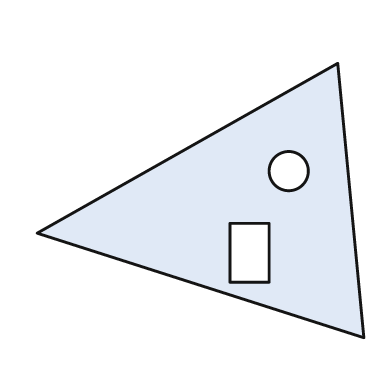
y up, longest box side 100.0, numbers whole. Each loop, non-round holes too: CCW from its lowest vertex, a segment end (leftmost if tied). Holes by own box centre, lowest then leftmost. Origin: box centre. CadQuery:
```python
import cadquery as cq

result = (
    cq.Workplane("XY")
    .moveTo(50.0, -42.0)
    .lineTo(42.0, 42.0)
    .lineTo(-50.0, -10.0)
    .close()
    .moveTo(9.0, -25.0)
    .lineTo(21.0, -25.0)
    .lineTo(21.0, -7.0)
    .lineTo(9.0, -7.0)
    .close()
    .moveTo(27.0, 9.0)
    .circle(6.0)
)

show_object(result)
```